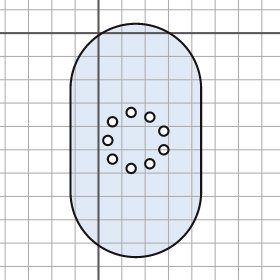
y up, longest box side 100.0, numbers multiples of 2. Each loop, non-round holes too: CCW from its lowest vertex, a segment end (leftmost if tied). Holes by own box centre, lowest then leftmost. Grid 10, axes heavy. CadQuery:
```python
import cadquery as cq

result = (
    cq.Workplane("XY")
    .moveTo(-12.0, -68.0)
    .threePointArc((16.0, -96.0), (44.0, -68.0))
    .lineTo(44.0, -24.0)
    .threePointArc((16.0, 4.0), (-12.0, -24.0))
    .close()
    .moveTo(14.0, -58.0)
    .circle(2.0)
    .moveTo(22.0, -56.0)
    .circle(2.0)
    .moveTo(6.0, -54.0)
    .circle(2.0)
    .moveTo(28.0, -50.0)
    .circle(2.0)
    .moveTo(4.0, -46.0)
    .circle(2.0)
    .moveTo(28.0, -42.0)
    .circle(2.0)
    .moveTo(6.0, -38.0)
    .circle(2.0)
    .moveTo(22.0, -36.0)
    .circle(2.0)
    .moveTo(14.0, -34.0)
    .circle(2.0)
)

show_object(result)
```